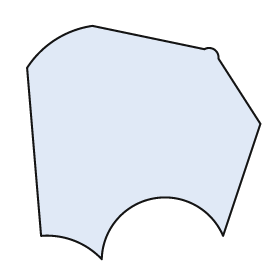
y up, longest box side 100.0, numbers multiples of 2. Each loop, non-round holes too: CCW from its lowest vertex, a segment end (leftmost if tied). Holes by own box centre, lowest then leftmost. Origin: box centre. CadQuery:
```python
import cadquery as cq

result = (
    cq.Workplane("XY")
    .moveTo(-18.0, -50.0)
    .threePointArc((4.0, -24.0), (34.0, -40.0))
    .lineTo(50.0, 8.0)
    .lineTo(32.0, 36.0)
    .threePointArc((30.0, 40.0), (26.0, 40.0))
    .lineTo(-22.0, 50.0)
    .threePointArc((-38.0, 44.0), (-50.0, 32.0))
    .lineTo(-44.0, -40.0)
    .threePointArc((-30.0, -42.0), (-18.0, -50.0))
    .close()
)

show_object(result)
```